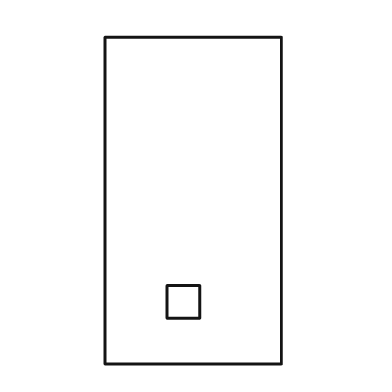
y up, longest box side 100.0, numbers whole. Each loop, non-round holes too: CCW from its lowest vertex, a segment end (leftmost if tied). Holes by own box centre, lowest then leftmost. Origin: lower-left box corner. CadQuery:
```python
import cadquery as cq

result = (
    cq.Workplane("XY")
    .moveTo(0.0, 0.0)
    .lineTo(54.0, 0.0)
    .lineTo(54.0, 100.0)
    .lineTo(0.0, 100.0)
    .close()
    .moveTo(19.0, 14.0)
    .lineTo(29.0, 14.0)
    .lineTo(29.0, 24.0)
    .lineTo(19.0, 24.0)
    .close()
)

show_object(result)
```